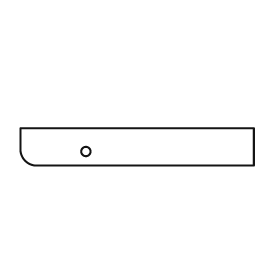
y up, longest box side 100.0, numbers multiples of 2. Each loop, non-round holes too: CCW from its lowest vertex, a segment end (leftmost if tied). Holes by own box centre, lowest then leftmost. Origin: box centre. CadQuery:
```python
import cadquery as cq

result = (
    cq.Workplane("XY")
    .moveTo(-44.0, -8.0)
    .lineTo(50.0, -8.0)
    .lineTo(50.0, 8.0)
    .lineTo(-50.0, 8.0)
    .lineTo(-50.0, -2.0)
    .threePointArc((-48.0, -6.0), (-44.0, -8.0))
    .close()
    .moveTo(-22.0, -2.0)
    .circle(2.0)
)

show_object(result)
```